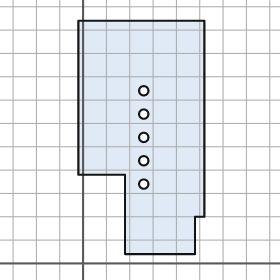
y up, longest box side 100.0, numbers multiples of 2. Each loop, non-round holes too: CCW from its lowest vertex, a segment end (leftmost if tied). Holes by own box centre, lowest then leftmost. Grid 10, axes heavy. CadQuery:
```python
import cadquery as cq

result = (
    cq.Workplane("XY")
    .moveTo(18.0, 4.0)
    .lineTo(48.0, 4.0)
    .lineTo(48.0, 20.0)
    .lineTo(52.0, 20.0)
    .lineTo(52.0, 104.0)
    .lineTo(-2.0, 104.0)
    .lineTo(-2.0, 38.0)
    .lineTo(18.0, 38.0)
    .close()
    .moveTo(26.0, 34.0)
    .circle(2.0)
    .moveTo(26.0, 44.0)
    .circle(2.0)
    .moveTo(26.0, 54.0)
    .circle(2.0)
    .moveTo(26.0, 64.0)
    .circle(2.0)
    .moveTo(26.0, 74.0)
    .circle(2.0)
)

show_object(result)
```